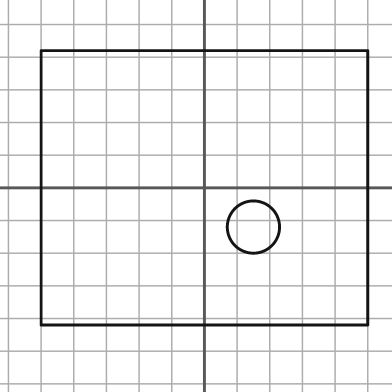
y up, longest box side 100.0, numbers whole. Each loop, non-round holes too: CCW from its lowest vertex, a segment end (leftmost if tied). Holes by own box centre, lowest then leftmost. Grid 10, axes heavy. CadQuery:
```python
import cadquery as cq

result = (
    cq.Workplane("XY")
    .moveTo(-50.0, -42.0)
    .lineTo(50.0, -42.0)
    .lineTo(50.0, 42.0)
    .lineTo(-50.0, 42.0)
    .close()
    .moveTo(15.0, -12.0)
    .circle(8.0)
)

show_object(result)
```